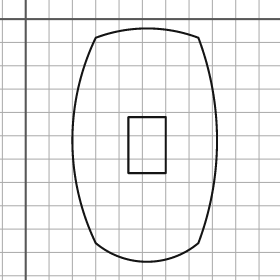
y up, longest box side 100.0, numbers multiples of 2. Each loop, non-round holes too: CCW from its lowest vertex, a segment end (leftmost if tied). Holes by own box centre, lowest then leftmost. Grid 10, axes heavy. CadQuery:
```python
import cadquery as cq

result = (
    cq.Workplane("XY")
    .moveTo(30.0, -96.0)
    .threePointArc((52.0, -104.0), (74.0, -96.0))
    .threePointArc((82.0, -52.0), (74.0, -8.0))
    .threePointArc((52.0, -4.0), (30.0, -8.0))
    .threePointArc((20.0, -52.0), (30.0, -96.0))
    .close()
    .moveTo(44.0, -66.0)
    .lineTo(60.0, -66.0)
    .lineTo(60.0, -42.0)
    .lineTo(44.0, -42.0)
    .close()
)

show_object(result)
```